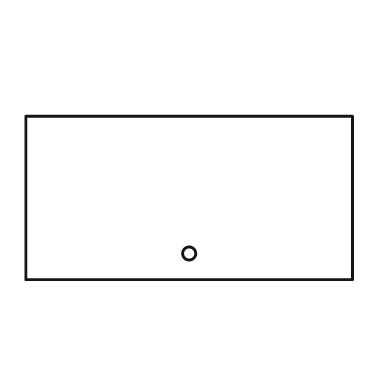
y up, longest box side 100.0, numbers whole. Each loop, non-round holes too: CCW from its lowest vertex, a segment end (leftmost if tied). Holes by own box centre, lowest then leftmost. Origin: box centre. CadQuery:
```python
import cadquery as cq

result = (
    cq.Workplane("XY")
    .moveTo(-50.0, -25.0)
    .lineTo(50.0, -25.0)
    .lineTo(50.0, 25.0)
    .lineTo(-50.0, 25.0)
    .close()
    .moveTo(0.0, -17.0)
    .circle(2.0)
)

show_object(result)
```